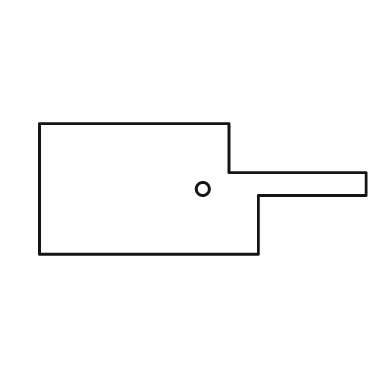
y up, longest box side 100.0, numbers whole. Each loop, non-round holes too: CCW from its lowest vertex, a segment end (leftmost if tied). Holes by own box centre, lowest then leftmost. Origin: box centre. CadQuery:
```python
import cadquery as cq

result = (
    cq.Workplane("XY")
    .moveTo(-50.0, -20.0)
    .lineTo(17.0, -20.0)
    .lineTo(17.0, -2.0)
    .lineTo(50.0, -2.0)
    .lineTo(50.0, 5.0)
    .lineTo(8.0, 5.0)
    .lineTo(8.0, 20.0)
    .lineTo(-50.0, 20.0)
    .close()
    .moveTo(0.0, 0.0)
    .circle(2.0)
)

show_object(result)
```